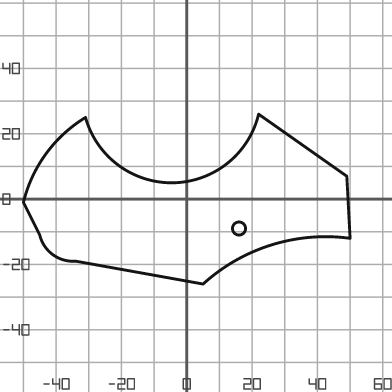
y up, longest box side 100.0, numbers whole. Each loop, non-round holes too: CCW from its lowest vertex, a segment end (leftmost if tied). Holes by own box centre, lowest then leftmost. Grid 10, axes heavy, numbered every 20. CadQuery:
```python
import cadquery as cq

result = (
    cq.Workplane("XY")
    .moveTo(5.0, -26.0)
    .threePointArc((26.0, -14.0), (50.0, -12.0))
    .lineTo(49.0, 7.0)
    .lineTo(22.0, 26.0)
    .threePointArc((-4.0, 5.0), (-31.0, 25.0))
    .threePointArc((-43.0, 14.0), (-50.0, -1.0))
    .lineTo(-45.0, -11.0)
    .threePointArc((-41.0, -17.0), (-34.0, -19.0))
    .close()
    .moveTo(16.0, -9.0)
    .circle(2.0)
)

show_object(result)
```